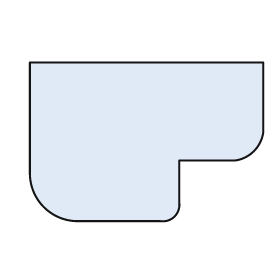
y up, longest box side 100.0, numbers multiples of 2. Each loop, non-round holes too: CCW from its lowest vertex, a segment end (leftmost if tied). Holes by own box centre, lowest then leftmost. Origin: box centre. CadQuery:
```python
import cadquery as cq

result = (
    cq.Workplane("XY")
    .moveTo(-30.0, -34.0)
    .lineTo(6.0, -34.0)
    .threePointArc((12.0, -32.0), (14.0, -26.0))
    .lineTo(14.0, -8.0)
    .lineTo(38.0, -8.0)
    .threePointArc((46.0, -4.0), (50.0, 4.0))
    .lineTo(50.0, 34.0)
    .lineTo(-50.0, 34.0)
    .lineTo(-50.0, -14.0)
    .threePointArc((-44.0, -28.0), (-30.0, -34.0))
    .close()
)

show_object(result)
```